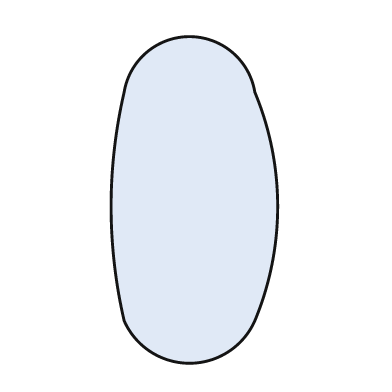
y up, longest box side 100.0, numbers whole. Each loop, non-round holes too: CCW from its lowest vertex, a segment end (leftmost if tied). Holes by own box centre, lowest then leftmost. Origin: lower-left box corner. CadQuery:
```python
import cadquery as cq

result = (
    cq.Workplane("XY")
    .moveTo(4.0, 13.0)
    .threePointArc((24.0, 0.0), (44.0, 13.0))
    .threePointArc((51.0, 48.0), (44.0, 83.0))
    .threePointArc((24.0, 100.0), (4.0, 83.0))
    .threePointArc((0.0, 48.0), (4.0, 13.0))
    .close()
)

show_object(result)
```